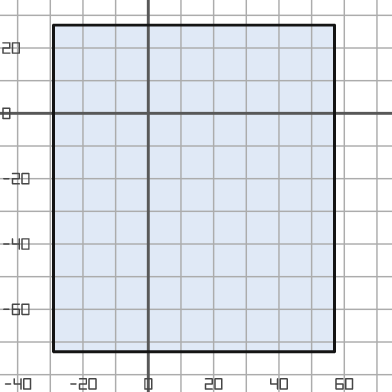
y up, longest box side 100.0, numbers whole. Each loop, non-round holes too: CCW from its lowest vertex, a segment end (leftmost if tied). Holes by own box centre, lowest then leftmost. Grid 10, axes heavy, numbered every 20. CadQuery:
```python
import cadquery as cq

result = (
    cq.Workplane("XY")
    .moveTo(-29.0, -73.0)
    .lineTo(57.0, -73.0)
    .lineTo(57.0, 27.0)
    .lineTo(-29.0, 27.0)
    .close()
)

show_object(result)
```